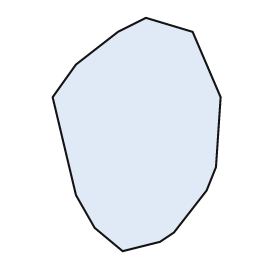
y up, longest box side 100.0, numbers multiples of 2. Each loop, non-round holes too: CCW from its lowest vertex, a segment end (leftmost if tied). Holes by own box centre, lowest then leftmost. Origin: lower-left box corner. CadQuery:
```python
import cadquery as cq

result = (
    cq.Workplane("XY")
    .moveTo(30.0, 0.0)
    .lineTo(46.0, 4.0)
    .lineTo(52.0, 8.0)
    .lineTo(66.0, 26.0)
    .lineTo(70.0, 36.0)
    .lineTo(72.0, 66.0)
    .lineTo(60.0, 94.0)
    .lineTo(40.0, 100.0)
    .lineTo(28.0, 94.0)
    .lineTo(10.0, 80.0)
    .lineTo(0.0, 66.0)
    .lineTo(10.0, 24.0)
    .lineTo(18.0, 10.0)
    .close()
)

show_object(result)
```